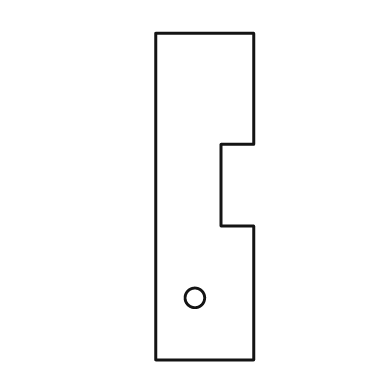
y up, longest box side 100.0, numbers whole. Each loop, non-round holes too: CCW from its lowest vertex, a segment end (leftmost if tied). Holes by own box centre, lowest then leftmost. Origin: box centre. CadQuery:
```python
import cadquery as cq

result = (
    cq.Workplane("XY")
    .moveTo(-15.0, -50.0)
    .lineTo(15.0, -50.0)
    .lineTo(15.0, -9.0)
    .lineTo(5.0, -9.0)
    .lineTo(5.0, 16.0)
    .lineTo(15.0, 16.0)
    .lineTo(15.0, 50.0)
    .lineTo(-15.0, 50.0)
    .close()
    .moveTo(-3.0, -31.0)
    .circle(3.0)
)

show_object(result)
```